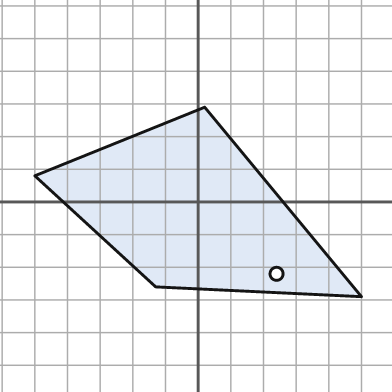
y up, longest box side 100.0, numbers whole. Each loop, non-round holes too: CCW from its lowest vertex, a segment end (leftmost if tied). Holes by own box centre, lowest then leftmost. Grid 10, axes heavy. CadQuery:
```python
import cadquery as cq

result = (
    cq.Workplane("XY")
    .moveTo(50.0, -29.0)
    .lineTo(2.0, 29.0)
    .lineTo(-50.0, 8.0)
    .lineTo(-13.0, -26.0)
    .close()
    .moveTo(24.0, -22.0)
    .circle(2.0)
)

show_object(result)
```